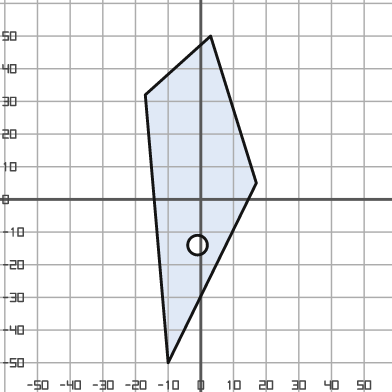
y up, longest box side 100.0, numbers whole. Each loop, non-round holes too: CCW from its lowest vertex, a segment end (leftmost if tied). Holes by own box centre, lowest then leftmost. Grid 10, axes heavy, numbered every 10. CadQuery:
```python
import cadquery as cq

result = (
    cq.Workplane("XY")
    .moveTo(-10.0, -50.0)
    .lineTo(17.0, 5.0)
    .lineTo(3.0, 50.0)
    .lineTo(-17.0, 32.0)
    .close()
    .moveTo(-1.0, -14.0)
    .circle(3.0)
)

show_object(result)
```